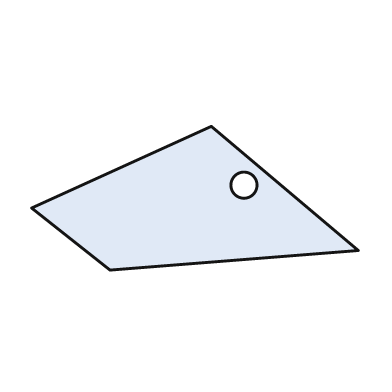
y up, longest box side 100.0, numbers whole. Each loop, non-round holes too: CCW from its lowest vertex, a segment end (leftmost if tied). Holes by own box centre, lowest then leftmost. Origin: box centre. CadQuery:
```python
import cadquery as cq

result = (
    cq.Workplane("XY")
    .moveTo(-26.0, -22.0)
    .lineTo(50.0, -16.0)
    .lineTo(5.0, 22.0)
    .lineTo(-50.0, -3.0)
    .close()
    .moveTo(15.0, 4.0)
    .circle(4.0)
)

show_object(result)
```